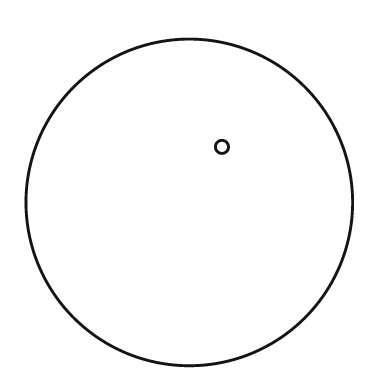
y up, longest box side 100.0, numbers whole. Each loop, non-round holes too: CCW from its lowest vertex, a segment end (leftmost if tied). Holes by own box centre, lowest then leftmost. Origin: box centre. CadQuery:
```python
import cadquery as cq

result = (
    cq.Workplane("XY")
    .moveTo(0.0, 0.0)
    .circle(50.0)
    .moveTo(10.0, 17.0)
    .circle(2.0)
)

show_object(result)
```